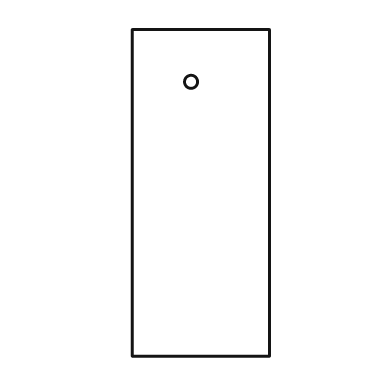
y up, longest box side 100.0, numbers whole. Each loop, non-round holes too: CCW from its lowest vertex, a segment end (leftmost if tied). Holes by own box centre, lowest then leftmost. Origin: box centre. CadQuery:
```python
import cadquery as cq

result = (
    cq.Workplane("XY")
    .moveTo(-21.0, -50.0)
    .lineTo(21.0, -50.0)
    .lineTo(21.0, 50.0)
    .lineTo(-21.0, 50.0)
    .close()
    .moveTo(-3.0, 34.0)
    .circle(2.0)
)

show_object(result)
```